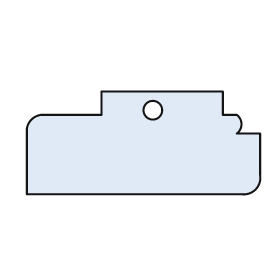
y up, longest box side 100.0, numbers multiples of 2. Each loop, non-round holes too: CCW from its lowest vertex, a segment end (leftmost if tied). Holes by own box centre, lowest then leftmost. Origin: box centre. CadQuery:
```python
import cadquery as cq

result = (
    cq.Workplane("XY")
    .moveTo(-50.0, -22.0)
    .lineTo(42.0, -22.0)
    .threePointArc((48.0, -20.0), (50.0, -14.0))
    .lineTo(50.0, 4.0)
    .lineTo(40.0, 4.0)
    .threePointArc((42.0, 8.0), (40.0, 12.0))
    .lineTo(34.0, 12.0)
    .lineTo(34.0, 22.0)
    .lineTo(-18.0, 22.0)
    .lineTo(-18.0, 12.0)
    .lineTo(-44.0, 12.0)
    .threePointArc((-48.0, 10.0), (-50.0, 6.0))
    .close()
    .moveTo(4.0, 14.0)
    .circle(4.0)
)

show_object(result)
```